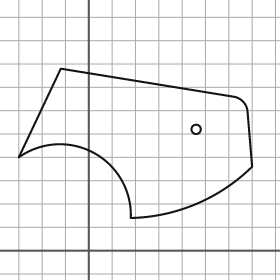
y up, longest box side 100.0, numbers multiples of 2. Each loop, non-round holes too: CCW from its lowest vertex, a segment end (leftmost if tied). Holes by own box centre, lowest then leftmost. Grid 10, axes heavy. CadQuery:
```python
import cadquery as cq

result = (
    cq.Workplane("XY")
    .moveTo(18.0, 14.0)
    .threePointArc((46.0, 20.0), (70.0, 36.0))
    .lineTo(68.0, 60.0)
    .threePointArc((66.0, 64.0), (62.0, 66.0))
    .lineTo(-12.0, 78.0)
    .lineTo(-30.0, 40.0)
    .threePointArc((2.0, 42.0), (18.0, 14.0))
    .close()
    .moveTo(46.0, 52.0)
    .circle(2.0)
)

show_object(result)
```